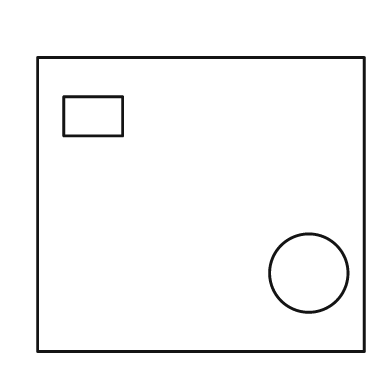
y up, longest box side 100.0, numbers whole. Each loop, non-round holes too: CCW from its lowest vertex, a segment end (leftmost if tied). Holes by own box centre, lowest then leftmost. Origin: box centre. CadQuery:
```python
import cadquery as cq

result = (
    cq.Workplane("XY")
    .moveTo(-50.0, -45.0)
    .lineTo(50.0, -45.0)
    .lineTo(50.0, 45.0)
    .lineTo(-50.0, 45.0)
    .close()
    .moveTo(33.0, -21.0)
    .circle(12.0)
    .moveTo(-42.0, 21.0)
    .lineTo(-24.0, 21.0)
    .lineTo(-24.0, 33.0)
    .lineTo(-42.0, 33.0)
    .close()
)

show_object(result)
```